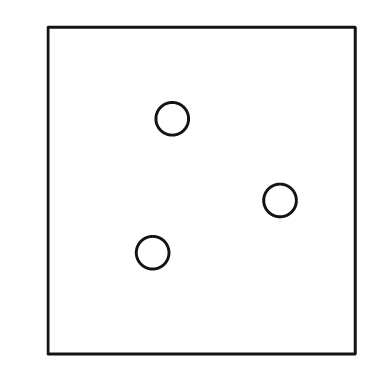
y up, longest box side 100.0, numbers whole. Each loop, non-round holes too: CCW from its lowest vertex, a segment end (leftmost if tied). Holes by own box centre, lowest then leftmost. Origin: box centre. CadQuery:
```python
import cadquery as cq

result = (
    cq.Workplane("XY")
    .moveTo(-47.0, -50.0)
    .lineTo(47.0, -50.0)
    .lineTo(47.0, 50.0)
    .lineTo(-47.0, 50.0)
    .close()
    .moveTo(-15.0, -19.0)
    .circle(5.0)
    .moveTo(24.0, -3.0)
    .circle(5.0)
    .moveTo(-9.0, 22.0)
    .circle(5.0)
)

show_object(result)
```